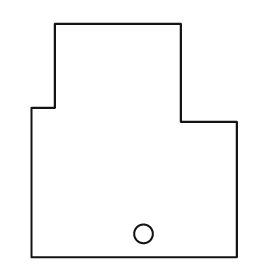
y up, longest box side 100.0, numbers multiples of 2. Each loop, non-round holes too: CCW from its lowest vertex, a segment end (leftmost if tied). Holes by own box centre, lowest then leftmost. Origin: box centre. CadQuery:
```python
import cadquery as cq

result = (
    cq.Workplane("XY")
    .moveTo(-44.0, -50.0)
    .lineTo(44.0, -50.0)
    .lineTo(44.0, 8.0)
    .lineTo(20.0, 8.0)
    .lineTo(20.0, 50.0)
    .lineTo(-34.0, 50.0)
    .lineTo(-34.0, 14.0)
    .lineTo(-44.0, 14.0)
    .close()
    .moveTo(4.0, -40.0)
    .circle(4.0)
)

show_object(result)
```